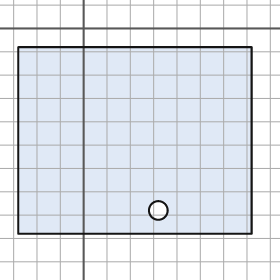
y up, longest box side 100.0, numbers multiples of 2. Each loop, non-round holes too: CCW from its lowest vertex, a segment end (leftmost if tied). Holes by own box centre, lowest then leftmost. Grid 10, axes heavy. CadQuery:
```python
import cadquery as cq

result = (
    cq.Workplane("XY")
    .moveTo(-28.0, -88.0)
    .lineTo(72.0, -88.0)
    .lineTo(72.0, -8.0)
    .lineTo(-28.0, -8.0)
    .close()
    .moveTo(32.0, -78.0)
    .circle(4.0)
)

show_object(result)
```